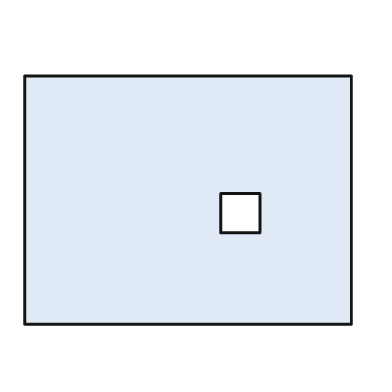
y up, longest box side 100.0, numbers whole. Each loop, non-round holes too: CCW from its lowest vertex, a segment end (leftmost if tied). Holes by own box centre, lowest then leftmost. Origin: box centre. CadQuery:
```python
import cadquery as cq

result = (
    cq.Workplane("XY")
    .moveTo(-50.0, -38.0)
    .lineTo(50.0, -38.0)
    .lineTo(50.0, 38.0)
    .lineTo(-50.0, 38.0)
    .close()
    .moveTo(10.0, -10.0)
    .lineTo(22.0, -10.0)
    .lineTo(22.0, 2.0)
    .lineTo(10.0, 2.0)
    .close()
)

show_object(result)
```